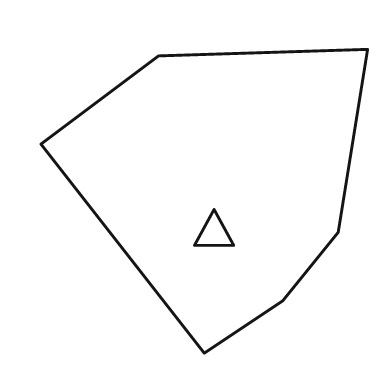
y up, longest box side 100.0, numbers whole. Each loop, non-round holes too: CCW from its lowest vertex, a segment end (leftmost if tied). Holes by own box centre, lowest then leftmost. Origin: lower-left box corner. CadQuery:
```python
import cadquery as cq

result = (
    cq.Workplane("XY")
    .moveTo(50.0, 0.0)
    .lineTo(74.0, 16.0)
    .lineTo(91.0, 37.0)
    .lineTo(100.0, 93.0)
    .lineTo(36.0, 91.0)
    .lineTo(0.0, 64.0)
    .close()
    .moveTo(47.0, 33.0)
    .lineTo(59.0, 33.0)
    .lineTo(53.0, 44.0)
    .close()
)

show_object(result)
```